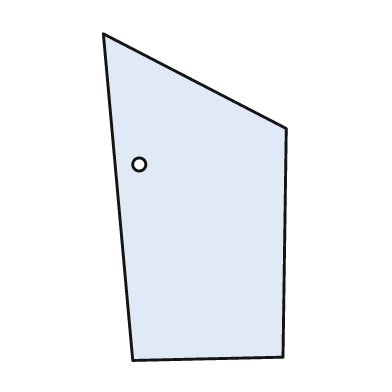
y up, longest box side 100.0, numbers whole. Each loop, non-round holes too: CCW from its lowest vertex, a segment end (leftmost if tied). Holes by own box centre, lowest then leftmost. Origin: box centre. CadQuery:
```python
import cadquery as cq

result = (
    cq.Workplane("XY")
    .moveTo(-19.0, -50.0)
    .lineTo(27.0, -49.0)
    .lineTo(28.0, 21.0)
    .lineTo(-28.0, 50.0)
    .close()
    .moveTo(-17.0, 10.0)
    .circle(2.0)
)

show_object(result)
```